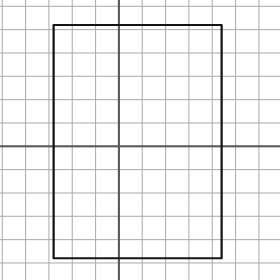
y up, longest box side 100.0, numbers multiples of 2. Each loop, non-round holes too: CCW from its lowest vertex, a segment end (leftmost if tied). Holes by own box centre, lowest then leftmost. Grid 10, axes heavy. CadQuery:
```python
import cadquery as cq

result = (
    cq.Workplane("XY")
    .moveTo(-28.0, -48.0)
    .lineTo(44.0, -48.0)
    .lineTo(44.0, 52.0)
    .lineTo(-28.0, 52.0)
    .close()
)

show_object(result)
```